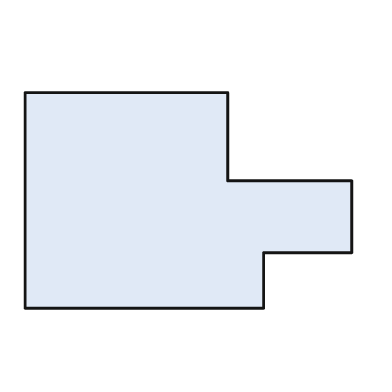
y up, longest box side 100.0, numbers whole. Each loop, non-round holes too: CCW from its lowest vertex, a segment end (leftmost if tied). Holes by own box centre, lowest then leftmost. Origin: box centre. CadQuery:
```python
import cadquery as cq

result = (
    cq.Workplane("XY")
    .moveTo(-50.0, -33.0)
    .lineTo(23.0, -33.0)
    .lineTo(23.0, -16.0)
    .lineTo(50.0, -16.0)
    .lineTo(50.0, 6.0)
    .lineTo(12.0, 6.0)
    .lineTo(12.0, 33.0)
    .lineTo(-50.0, 33.0)
    .close()
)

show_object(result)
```